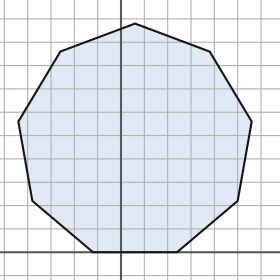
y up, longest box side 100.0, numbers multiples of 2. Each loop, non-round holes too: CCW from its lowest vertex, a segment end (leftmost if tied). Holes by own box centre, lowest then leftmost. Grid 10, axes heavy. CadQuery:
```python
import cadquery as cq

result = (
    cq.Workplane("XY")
    .moveTo(-12.0, 0.0)
    .lineTo(24.0, 0.0)
    .lineTo(50.0, 22.0)
    .lineTo(56.0, 56.0)
    .lineTo(38.0, 86.0)
    .lineTo(6.0, 98.0)
    .lineTo(-26.0, 86.0)
    .lineTo(-44.0, 56.0)
    .lineTo(-38.0, 22.0)
    .close()
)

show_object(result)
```